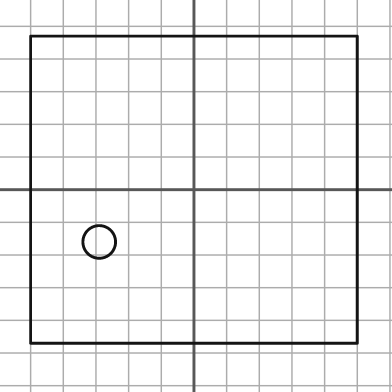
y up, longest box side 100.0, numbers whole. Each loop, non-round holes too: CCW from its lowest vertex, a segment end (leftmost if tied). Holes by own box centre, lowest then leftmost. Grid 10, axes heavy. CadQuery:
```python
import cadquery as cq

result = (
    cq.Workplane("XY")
    .moveTo(-50.0, -47.0)
    .lineTo(50.0, -47.0)
    .lineTo(50.0, 47.0)
    .lineTo(-50.0, 47.0)
    .close()
    .moveTo(-29.0, -16.0)
    .circle(5.0)
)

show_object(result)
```